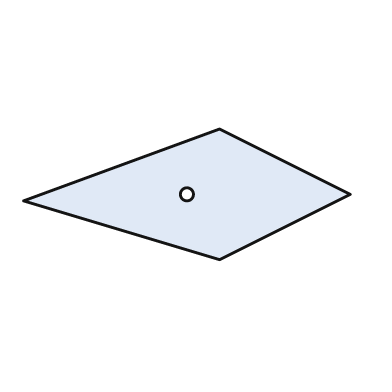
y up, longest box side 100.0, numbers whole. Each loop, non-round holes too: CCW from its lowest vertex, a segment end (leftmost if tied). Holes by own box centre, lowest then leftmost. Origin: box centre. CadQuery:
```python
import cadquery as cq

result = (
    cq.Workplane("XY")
    .moveTo(10.0, -20.0)
    .lineTo(50.0, 0.0)
    .lineTo(10.0, 20.0)
    .lineTo(-50.0, -2.0)
    .close()
    .moveTo(0.0, 0.0)
    .circle(2.0)
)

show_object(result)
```